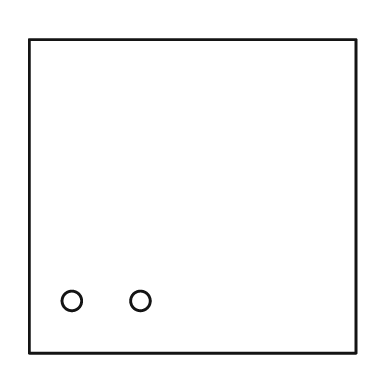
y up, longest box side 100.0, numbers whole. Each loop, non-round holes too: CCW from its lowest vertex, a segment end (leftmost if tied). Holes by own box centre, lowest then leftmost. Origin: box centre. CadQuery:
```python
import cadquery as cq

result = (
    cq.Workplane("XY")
    .moveTo(-50.0, -48.0)
    .lineTo(50.0, -48.0)
    .lineTo(50.0, 48.0)
    .lineTo(-50.0, 48.0)
    .close()
    .moveTo(-37.0, -32.0)
    .circle(3.0)
    .moveTo(-16.0, -32.0)
    .circle(3.0)
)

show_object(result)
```